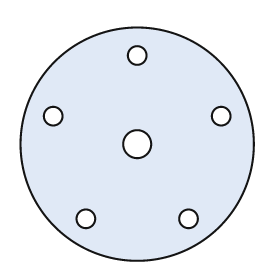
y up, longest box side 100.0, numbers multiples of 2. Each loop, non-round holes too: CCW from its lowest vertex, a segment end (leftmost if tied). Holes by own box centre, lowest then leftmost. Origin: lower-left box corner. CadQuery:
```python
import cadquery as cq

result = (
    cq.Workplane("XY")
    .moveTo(50.0, 50.0)
    .circle(50.0)
    .moveTo(28.0, 18.0)
    .circle(4.0)
    .moveTo(72.0, 18.0)
    .circle(4.0)
    .moveTo(50.0, 50.0)
    .circle(6.0)
    .moveTo(14.0, 62.0)
    .circle(4.0)
    .moveTo(86.0, 62.0)
    .circle(4.0)
    .moveTo(50.0, 88.0)
    .circle(4.0)
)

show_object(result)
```